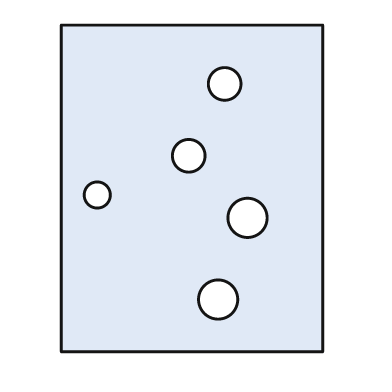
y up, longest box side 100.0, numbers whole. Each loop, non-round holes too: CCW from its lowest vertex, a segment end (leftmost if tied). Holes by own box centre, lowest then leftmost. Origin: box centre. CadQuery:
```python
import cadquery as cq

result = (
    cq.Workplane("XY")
    .moveTo(-40.0, -50.0)
    .lineTo(40.0, -50.0)
    .lineTo(40.0, 50.0)
    .lineTo(-40.0, 50.0)
    .close()
    .moveTo(8.0, -34.0)
    .circle(6.0)
    .moveTo(17.0, -9.0)
    .circle(6.0)
    .moveTo(-29.0, -2.0)
    .circle(4.0)
    .moveTo(-1.0, 10.0)
    .circle(5.0)
    .moveTo(10.0, 32.0)
    .circle(5.0)
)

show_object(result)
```